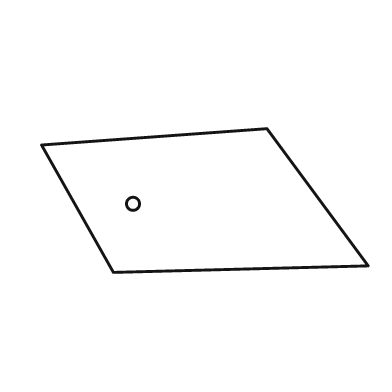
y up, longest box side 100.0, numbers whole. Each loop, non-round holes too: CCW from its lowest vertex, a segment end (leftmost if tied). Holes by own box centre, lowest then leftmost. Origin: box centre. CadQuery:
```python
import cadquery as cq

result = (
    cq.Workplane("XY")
    .moveTo(-28.0, -22.0)
    .lineTo(50.0, -20.0)
    .lineTo(19.0, 22.0)
    .lineTo(-50.0, 17.0)
    .close()
    .moveTo(-22.0, -1.0)
    .circle(2.0)
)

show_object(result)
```